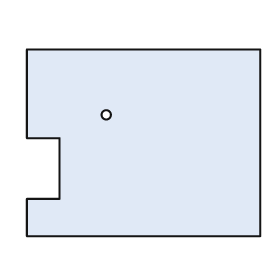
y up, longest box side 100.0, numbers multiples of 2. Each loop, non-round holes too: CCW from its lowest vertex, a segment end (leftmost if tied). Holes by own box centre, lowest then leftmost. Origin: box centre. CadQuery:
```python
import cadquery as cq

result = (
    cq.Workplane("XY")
    .moveTo(-50.0, -40.0)
    .lineTo(50.0, -40.0)
    .lineTo(50.0, 40.0)
    .lineTo(-50.0, 40.0)
    .lineTo(-50.0, 2.0)
    .lineTo(-36.0, 2.0)
    .lineTo(-36.0, -24.0)
    .lineTo(-50.0, -24.0)
    .close()
    .moveTo(-16.0, 12.0)
    .circle(2.0)
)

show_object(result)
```